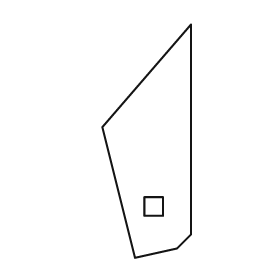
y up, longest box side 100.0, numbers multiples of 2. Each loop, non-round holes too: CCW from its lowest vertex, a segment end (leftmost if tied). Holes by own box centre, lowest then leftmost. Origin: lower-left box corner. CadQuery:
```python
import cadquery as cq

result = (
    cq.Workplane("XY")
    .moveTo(14.0, 0.0)
    .lineTo(32.0, 4.0)
    .lineTo(38.0, 10.0)
    .lineTo(38.0, 100.0)
    .lineTo(0.0, 56.0)
    .close()
    .moveTo(18.0, 18.0)
    .lineTo(26.0, 18.0)
    .lineTo(26.0, 26.0)
    .lineTo(18.0, 26.0)
    .close()
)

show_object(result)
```